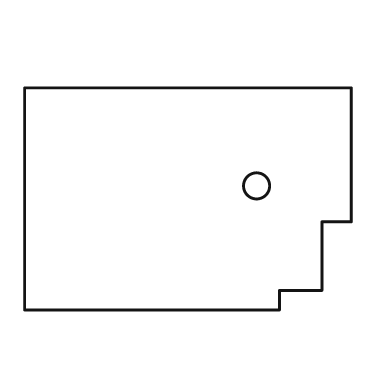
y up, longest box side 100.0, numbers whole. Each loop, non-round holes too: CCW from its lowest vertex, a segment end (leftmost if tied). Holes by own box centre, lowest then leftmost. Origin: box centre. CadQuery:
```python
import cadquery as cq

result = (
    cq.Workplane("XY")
    .moveTo(-50.0, -34.0)
    .lineTo(28.0, -34.0)
    .lineTo(28.0, -28.0)
    .lineTo(41.0, -28.0)
    .lineTo(41.0, -7.0)
    .lineTo(50.0, -7.0)
    .lineTo(50.0, 34.0)
    .lineTo(-50.0, 34.0)
    .close()
    .moveTo(21.0, 4.0)
    .circle(4.0)
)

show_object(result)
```